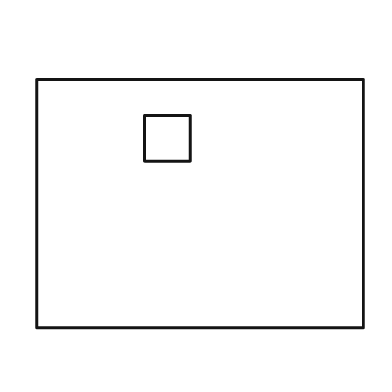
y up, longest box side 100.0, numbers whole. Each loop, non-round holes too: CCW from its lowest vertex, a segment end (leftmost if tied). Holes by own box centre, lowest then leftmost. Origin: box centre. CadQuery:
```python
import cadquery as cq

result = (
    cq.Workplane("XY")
    .moveTo(-50.0, -38.0)
    .lineTo(50.0, -38.0)
    .lineTo(50.0, 38.0)
    .lineTo(-50.0, 38.0)
    .close()
    .moveTo(-17.0, 13.0)
    .lineTo(-3.0, 13.0)
    .lineTo(-3.0, 27.0)
    .lineTo(-17.0, 27.0)
    .close()
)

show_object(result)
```